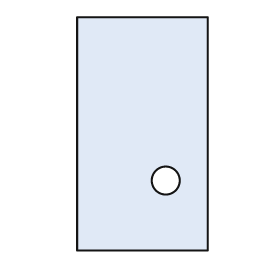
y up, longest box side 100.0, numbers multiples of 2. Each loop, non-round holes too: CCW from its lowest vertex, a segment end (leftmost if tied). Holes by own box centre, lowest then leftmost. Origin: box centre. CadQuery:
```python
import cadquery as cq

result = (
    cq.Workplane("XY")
    .moveTo(-28.0, -50.0)
    .lineTo(28.0, -50.0)
    .lineTo(28.0, 50.0)
    .lineTo(-28.0, 50.0)
    .close()
    .moveTo(10.0, -20.0)
    .circle(6.0)
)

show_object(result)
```